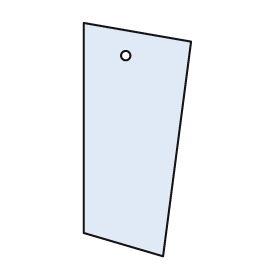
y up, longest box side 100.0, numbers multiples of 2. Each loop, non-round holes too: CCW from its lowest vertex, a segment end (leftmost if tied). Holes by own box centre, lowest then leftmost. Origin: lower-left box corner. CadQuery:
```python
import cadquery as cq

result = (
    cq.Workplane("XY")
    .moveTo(34.0, 0.0)
    .lineTo(46.0, 92.0)
    .lineTo(0.0, 100.0)
    .lineTo(0.0, 10.0)
    .close()
    .moveTo(18.0, 86.0)
    .circle(2.0)
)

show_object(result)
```